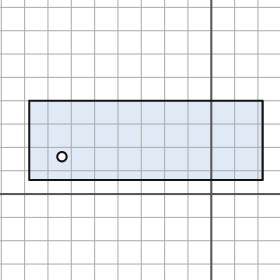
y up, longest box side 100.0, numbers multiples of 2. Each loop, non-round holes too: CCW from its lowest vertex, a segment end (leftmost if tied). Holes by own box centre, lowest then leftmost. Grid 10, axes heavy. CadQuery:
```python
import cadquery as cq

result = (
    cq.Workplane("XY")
    .moveTo(-78.0, 6.0)
    .lineTo(22.0, 6.0)
    .lineTo(22.0, 40.0)
    .lineTo(-78.0, 40.0)
    .close()
    .moveTo(-64.0, 16.0)
    .circle(2.0)
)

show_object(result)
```